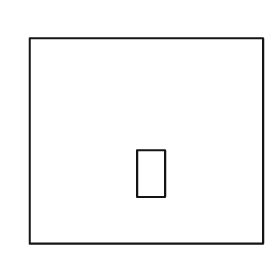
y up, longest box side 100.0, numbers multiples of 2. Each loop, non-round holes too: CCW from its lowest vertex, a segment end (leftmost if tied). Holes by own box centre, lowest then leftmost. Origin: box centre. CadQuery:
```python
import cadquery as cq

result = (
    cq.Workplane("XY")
    .moveTo(-50.0, -44.0)
    .lineTo(50.0, -44.0)
    .lineTo(50.0, 44.0)
    .lineTo(-50.0, 44.0)
    .close()
    .moveTo(-4.0, -24.0)
    .lineTo(8.0, -24.0)
    .lineTo(8.0, -4.0)
    .lineTo(-4.0, -4.0)
    .close()
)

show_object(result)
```